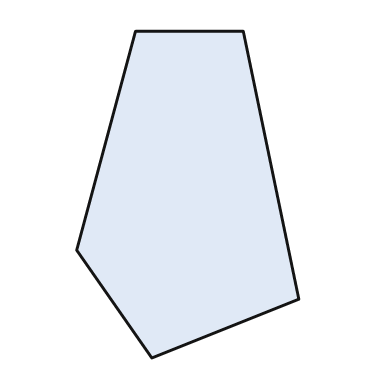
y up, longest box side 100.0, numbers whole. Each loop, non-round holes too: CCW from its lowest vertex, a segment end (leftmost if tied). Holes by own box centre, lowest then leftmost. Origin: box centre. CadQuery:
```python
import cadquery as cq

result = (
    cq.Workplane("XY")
    .moveTo(-11.0, -50.0)
    .lineTo(34.0, -32.0)
    .lineTo(17.0, 50.0)
    .lineTo(-16.0, 50.0)
    .lineTo(-34.0, -17.0)
    .close()
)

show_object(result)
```